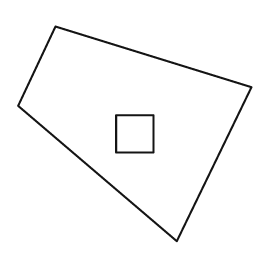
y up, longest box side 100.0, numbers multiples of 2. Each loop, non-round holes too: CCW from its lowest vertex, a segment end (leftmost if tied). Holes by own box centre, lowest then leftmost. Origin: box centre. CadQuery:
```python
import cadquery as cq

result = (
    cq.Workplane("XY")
    .moveTo(18.0, -46.0)
    .lineTo(50.0, 20.0)
    .lineTo(-34.0, 46.0)
    .lineTo(-50.0, 12.0)
    .close()
    .moveTo(-8.0, -8.0)
    .lineTo(8.0, -8.0)
    .lineTo(8.0, 8.0)
    .lineTo(-8.0, 8.0)
    .close()
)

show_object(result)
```